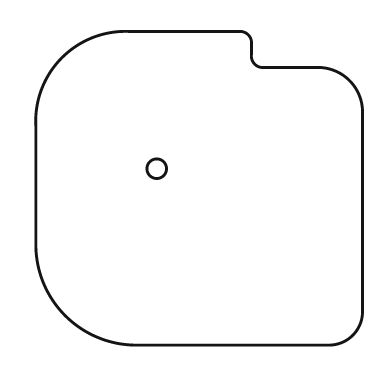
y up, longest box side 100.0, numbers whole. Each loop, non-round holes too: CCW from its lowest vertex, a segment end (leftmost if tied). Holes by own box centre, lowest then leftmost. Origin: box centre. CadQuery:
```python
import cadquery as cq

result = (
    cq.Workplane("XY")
    .moveTo(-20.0, -48.0)
    .lineTo(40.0, -48.0)
    .threePointArc((47.0, -45.0), (50.0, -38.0))
    .lineTo(50.0, 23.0)
    .threePointArc((46.0, 33.0), (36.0, 37.0))
    .lineTo(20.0, 37.0)
    .threePointArc((17.0, 38.0), (16.0, 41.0))
    .lineTo(16.0, 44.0)
    .threePointArc((15.0, 47.0), (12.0, 48.0))
    .lineTo(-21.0, 48.0)
    .threePointArc((-42.0, 40.0), (-50.0, 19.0))
    .lineTo(-50.0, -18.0)
    .threePointArc((-41.0, -39.0), (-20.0, -48.0))
    .close()
    .moveTo(-13.0, 6.0)
    .circle(3.0)
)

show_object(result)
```